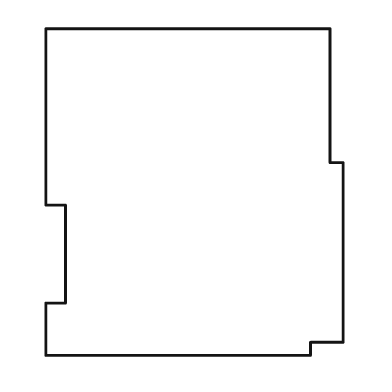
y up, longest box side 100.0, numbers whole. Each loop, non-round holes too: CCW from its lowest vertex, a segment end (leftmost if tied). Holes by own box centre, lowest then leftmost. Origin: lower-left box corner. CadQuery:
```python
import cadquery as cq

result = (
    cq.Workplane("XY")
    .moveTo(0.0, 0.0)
    .lineTo(81.0, 0.0)
    .lineTo(81.0, 4.0)
    .lineTo(91.0, 4.0)
    .lineTo(91.0, 59.0)
    .lineTo(87.0, 59.0)
    .lineTo(87.0, 100.0)
    .lineTo(0.0, 100.0)
    .lineTo(0.0, 46.0)
    .lineTo(6.0, 46.0)
    .lineTo(6.0, 16.0)
    .lineTo(0.0, 16.0)
    .close()
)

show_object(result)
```